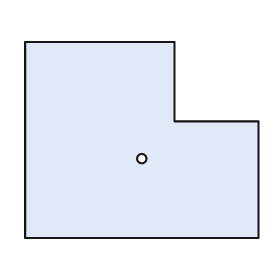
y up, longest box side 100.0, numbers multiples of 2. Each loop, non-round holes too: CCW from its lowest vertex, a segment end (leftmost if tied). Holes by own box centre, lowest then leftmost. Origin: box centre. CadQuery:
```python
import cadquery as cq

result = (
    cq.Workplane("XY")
    .moveTo(-50.0, -42.0)
    .lineTo(50.0, -42.0)
    .lineTo(50.0, 8.0)
    .lineTo(14.0, 8.0)
    .lineTo(14.0, 42.0)
    .lineTo(-50.0, 42.0)
    .close()
    .moveTo(0.0, -8.0)
    .circle(2.0)
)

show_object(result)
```